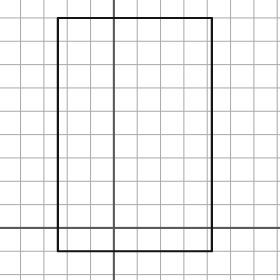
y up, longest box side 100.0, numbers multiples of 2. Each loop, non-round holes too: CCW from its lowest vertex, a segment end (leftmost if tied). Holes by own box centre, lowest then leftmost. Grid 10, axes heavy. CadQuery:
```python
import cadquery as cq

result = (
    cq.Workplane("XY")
    .moveTo(-24.0, -10.0)
    .lineTo(42.0, -10.0)
    .lineTo(42.0, 90.0)
    .lineTo(-24.0, 90.0)
    .close()
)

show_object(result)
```